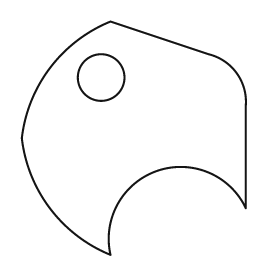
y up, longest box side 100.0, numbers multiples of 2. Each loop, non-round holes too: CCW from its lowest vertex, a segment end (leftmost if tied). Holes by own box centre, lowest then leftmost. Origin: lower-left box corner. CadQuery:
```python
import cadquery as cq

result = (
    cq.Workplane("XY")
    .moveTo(38.0, 0.0)
    .threePointArc((58.0, 36.0), (96.0, 20.0))
    .lineTo(96.0, 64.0)
    .threePointArc((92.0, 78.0), (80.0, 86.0))
    .lineTo(38.0, 100.0)
    .threePointArc((12.0, 80.0), (0.0, 50.0))
    .threePointArc((12.0, 20.0), (38.0, 0.0))
    .close()
    .moveTo(34.0, 76.0)
    .circle(10.0)
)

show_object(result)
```